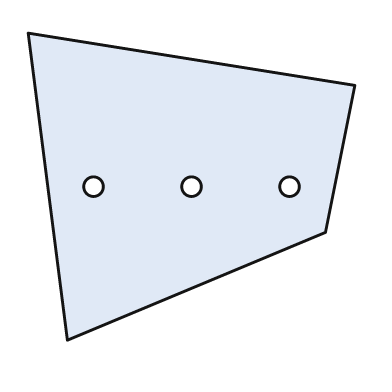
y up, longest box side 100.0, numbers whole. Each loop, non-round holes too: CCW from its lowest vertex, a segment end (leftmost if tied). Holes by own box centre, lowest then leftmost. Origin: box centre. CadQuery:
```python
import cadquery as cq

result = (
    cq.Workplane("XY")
    .moveTo(-38.0, -47.0)
    .lineTo(41.0, -14.0)
    .lineTo(50.0, 31.0)
    .lineTo(-50.0, 47.0)
    .close()
    .moveTo(-30.0, 0.0)
    .circle(3.0)
    .moveTo(0.0, 0.0)
    .circle(3.0)
    .moveTo(30.0, 0.0)
    .circle(3.0)
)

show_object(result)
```